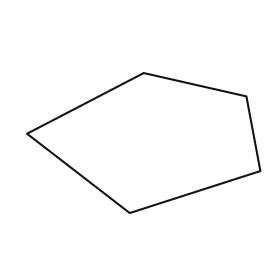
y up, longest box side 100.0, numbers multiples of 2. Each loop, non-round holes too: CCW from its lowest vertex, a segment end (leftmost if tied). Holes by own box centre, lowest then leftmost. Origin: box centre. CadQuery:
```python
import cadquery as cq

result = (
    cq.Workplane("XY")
    .moveTo(-6.0, -30.0)
    .lineTo(50.0, -12.0)
    .lineTo(44.0, 20.0)
    .lineTo(0.0, 30.0)
    .lineTo(-50.0, 4.0)
    .close()
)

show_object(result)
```